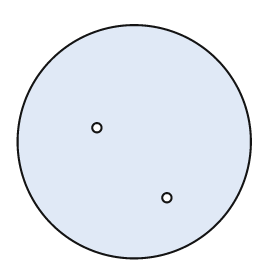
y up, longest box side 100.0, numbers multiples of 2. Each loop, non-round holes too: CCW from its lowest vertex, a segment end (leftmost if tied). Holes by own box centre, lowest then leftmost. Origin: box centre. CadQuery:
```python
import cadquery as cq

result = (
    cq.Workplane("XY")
    .moveTo(0.0, 0.0)
    .circle(50.0)
    .moveTo(14.0, -24.0)
    .circle(2.0)
    .moveTo(-16.0, 6.0)
    .circle(2.0)
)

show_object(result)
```